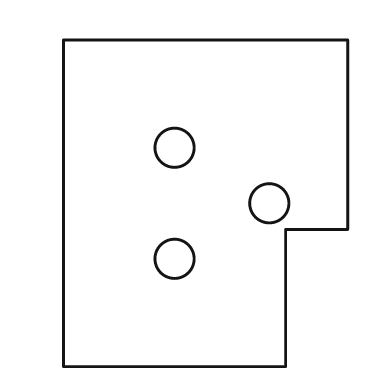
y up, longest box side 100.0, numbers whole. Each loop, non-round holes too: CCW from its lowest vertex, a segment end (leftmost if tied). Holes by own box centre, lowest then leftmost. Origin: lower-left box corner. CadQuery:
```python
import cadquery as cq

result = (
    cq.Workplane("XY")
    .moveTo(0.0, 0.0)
    .lineTo(68.0, 0.0)
    .lineTo(68.0, 42.0)
    .lineTo(87.0, 42.0)
    .lineTo(87.0, 100.0)
    .lineTo(0.0, 100.0)
    .close()
    .moveTo(34.0, 33.0)
    .circle(6.0)
    .moveTo(63.0, 50.0)
    .circle(6.0)
    .moveTo(34.0, 67.0)
    .circle(6.0)
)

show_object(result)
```